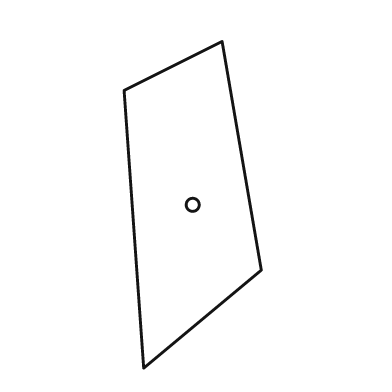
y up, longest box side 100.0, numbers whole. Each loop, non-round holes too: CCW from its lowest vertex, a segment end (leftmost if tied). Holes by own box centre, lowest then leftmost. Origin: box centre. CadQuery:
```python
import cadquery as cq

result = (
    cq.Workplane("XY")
    .moveTo(-15.0, -50.0)
    .lineTo(21.0, -20.0)
    .lineTo(9.0, 50.0)
    .lineTo(-21.0, 35.0)
    .close()
    .moveTo(0.0, 0.0)
    .circle(2.0)
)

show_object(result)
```